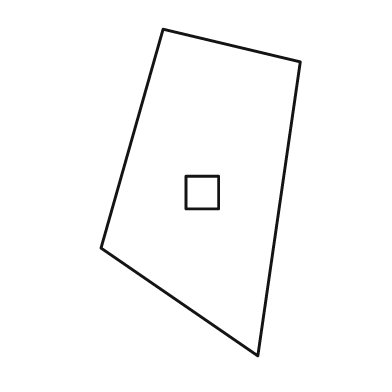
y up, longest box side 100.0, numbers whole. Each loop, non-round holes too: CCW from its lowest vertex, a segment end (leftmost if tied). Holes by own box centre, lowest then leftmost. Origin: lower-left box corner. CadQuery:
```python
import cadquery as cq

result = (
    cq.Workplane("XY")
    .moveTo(48.0, 0.0)
    .lineTo(61.0, 90.0)
    .lineTo(19.0, 100.0)
    .lineTo(0.0, 33.0)
    .close()
    .moveTo(26.0, 45.0)
    .lineTo(36.0, 45.0)
    .lineTo(36.0, 55.0)
    .lineTo(26.0, 55.0)
    .close()
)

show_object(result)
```